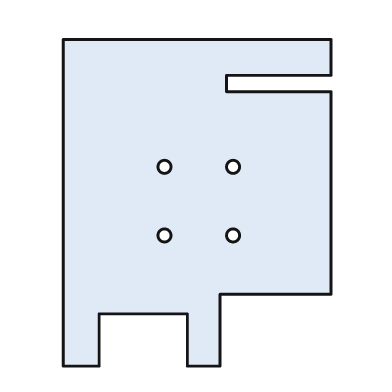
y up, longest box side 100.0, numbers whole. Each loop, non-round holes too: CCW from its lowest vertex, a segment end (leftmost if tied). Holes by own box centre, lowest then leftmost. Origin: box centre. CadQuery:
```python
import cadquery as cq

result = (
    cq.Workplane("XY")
    .moveTo(-41.0, -50.0)
    .lineTo(-30.0, -50.0)
    .lineTo(-30.0, -34.0)
    .lineTo(-3.0, -34.0)
    .lineTo(-3.0, -50.0)
    .lineTo(7.0, -50.0)
    .lineTo(7.0, -28.0)
    .lineTo(41.0, -28.0)
    .lineTo(41.0, 34.0)
    .lineTo(9.0, 34.0)
    .lineTo(9.0, 39.0)
    .lineTo(41.0, 39.0)
    .lineTo(41.0, 50.0)
    .lineTo(-41.0, 50.0)
    .close()
    .moveTo(-10.0, -10.0)
    .circle(2.0)
    .moveTo(11.0, -10.0)
    .circle(2.0)
    .moveTo(-10.0, 11.0)
    .circle(2.0)
    .moveTo(11.0, 11.0)
    .circle(2.0)
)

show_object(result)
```